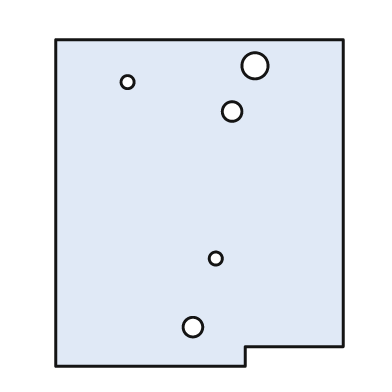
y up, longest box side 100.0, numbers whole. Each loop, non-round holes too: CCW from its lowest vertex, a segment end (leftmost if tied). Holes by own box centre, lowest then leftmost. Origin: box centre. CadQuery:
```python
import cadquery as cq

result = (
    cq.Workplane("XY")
    .moveTo(-44.0, -50.0)
    .lineTo(14.0, -50.0)
    .lineTo(14.0, -44.0)
    .lineTo(44.0, -44.0)
    .lineTo(44.0, 50.0)
    .lineTo(-44.0, 50.0)
    .close()
    .moveTo(-2.0, -38.0)
    .circle(3.0)
    .moveTo(5.0, -17.0)
    .circle(2.0)
    .moveTo(10.0, 28.0)
    .circle(3.0)
    .moveTo(-22.0, 37.0)
    .circle(2.0)
    .moveTo(17.0, 42.0)
    .circle(4.0)
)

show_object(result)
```